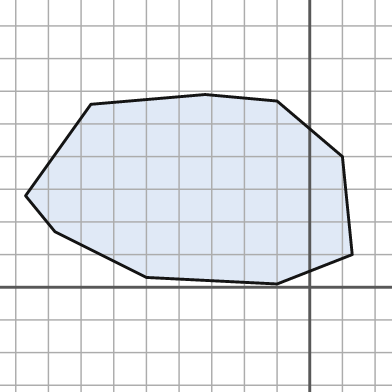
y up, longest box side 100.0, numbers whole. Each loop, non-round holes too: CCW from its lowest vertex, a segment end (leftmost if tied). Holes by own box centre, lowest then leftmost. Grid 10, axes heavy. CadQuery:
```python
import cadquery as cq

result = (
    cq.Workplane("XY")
    .moveTo(-10.0, 1.0)
    .lineTo(13.0, 10.0)
    .lineTo(10.0, 40.0)
    .lineTo(-10.0, 57.0)
    .lineTo(-32.0, 59.0)
    .lineTo(-67.0, 56.0)
    .lineTo(-87.0, 28.0)
    .lineTo(-78.0, 17.0)
    .lineTo(-50.0, 3.0)
    .close()
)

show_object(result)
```